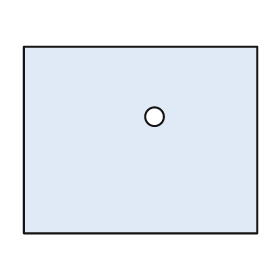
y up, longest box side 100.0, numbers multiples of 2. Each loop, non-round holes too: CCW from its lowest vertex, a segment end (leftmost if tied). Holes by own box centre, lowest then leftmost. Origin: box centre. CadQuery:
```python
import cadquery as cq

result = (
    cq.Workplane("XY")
    .moveTo(-50.0, -40.0)
    .lineTo(50.0, -40.0)
    .lineTo(50.0, 40.0)
    .lineTo(-50.0, 40.0)
    .close()
    .moveTo(6.0, 10.0)
    .circle(4.0)
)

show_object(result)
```